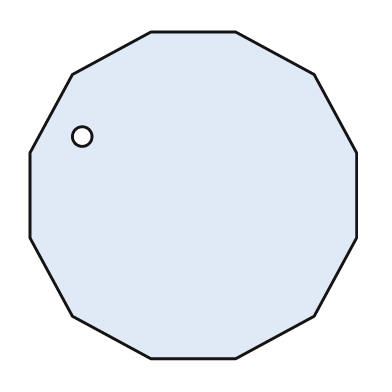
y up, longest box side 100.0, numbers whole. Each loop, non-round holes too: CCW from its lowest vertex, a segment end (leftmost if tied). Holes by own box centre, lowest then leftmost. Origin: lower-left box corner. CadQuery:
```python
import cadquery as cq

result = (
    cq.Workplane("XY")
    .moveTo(37.0, 0.0)
    .lineTo(63.0, 0.0)
    .lineTo(87.0, 13.0)
    .lineTo(100.0, 37.0)
    .lineTo(100.0, 63.0)
    .lineTo(87.0, 87.0)
    .lineTo(63.0, 100.0)
    .lineTo(37.0, 100.0)
    .lineTo(13.0, 87.0)
    .lineTo(0.0, 63.0)
    .lineTo(0.0, 37.0)
    .lineTo(13.0, 13.0)
    .close()
    .moveTo(16.0, 68.0)
    .circle(3.0)
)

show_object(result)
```